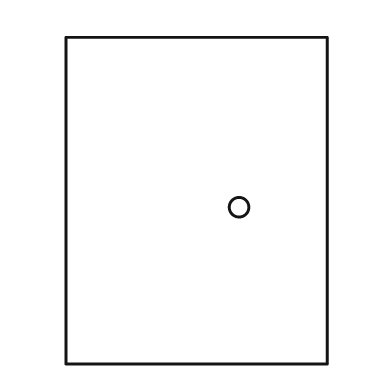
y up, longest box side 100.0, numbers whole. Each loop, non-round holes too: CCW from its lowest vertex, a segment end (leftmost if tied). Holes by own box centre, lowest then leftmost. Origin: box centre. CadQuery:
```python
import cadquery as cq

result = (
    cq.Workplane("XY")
    .moveTo(-40.0, -50.0)
    .lineTo(40.0, -50.0)
    .lineTo(40.0, 50.0)
    .lineTo(-40.0, 50.0)
    .close()
    .moveTo(13.0, -2.0)
    .circle(3.0)
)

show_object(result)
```